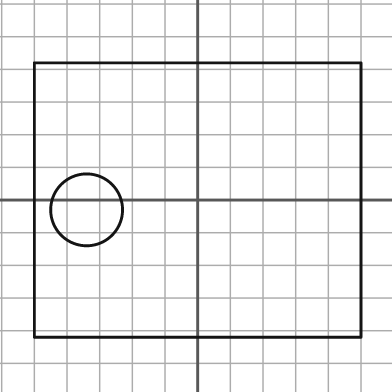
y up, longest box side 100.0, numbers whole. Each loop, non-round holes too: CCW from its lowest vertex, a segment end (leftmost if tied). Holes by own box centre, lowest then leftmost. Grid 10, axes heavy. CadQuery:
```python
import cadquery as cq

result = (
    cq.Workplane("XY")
    .moveTo(-50.0, -42.0)
    .lineTo(50.0, -42.0)
    .lineTo(50.0, 42.0)
    .lineTo(-50.0, 42.0)
    .close()
    .moveTo(-34.0, -3.0)
    .circle(11.0)
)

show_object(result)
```